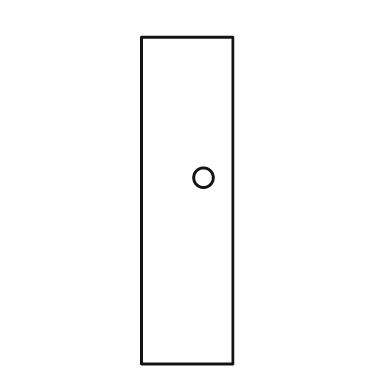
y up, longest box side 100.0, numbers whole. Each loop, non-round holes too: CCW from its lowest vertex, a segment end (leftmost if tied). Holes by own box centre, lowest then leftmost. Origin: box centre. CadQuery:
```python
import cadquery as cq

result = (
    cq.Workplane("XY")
    .moveTo(-14.0, -50.0)
    .lineTo(14.0, -50.0)
    .lineTo(14.0, 50.0)
    .lineTo(-14.0, 50.0)
    .close()
    .moveTo(5.0, 7.0)
    .circle(3.0)
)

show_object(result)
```